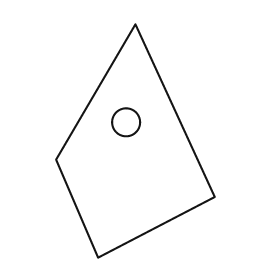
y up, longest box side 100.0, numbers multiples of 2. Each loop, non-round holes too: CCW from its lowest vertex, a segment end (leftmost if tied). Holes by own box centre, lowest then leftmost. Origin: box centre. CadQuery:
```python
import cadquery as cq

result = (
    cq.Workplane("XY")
    .moveTo(-16.0, -50.0)
    .lineTo(34.0, -24.0)
    .lineTo(0.0, 50.0)
    .lineTo(-34.0, -8.0)
    .close()
    .moveTo(-4.0, 8.0)
    .circle(6.0)
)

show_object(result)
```